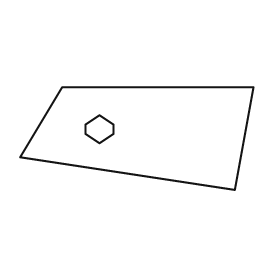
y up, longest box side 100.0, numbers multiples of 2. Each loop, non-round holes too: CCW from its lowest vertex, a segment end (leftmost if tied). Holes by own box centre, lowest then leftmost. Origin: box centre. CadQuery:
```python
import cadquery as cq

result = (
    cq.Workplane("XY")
    .moveTo(42.0, -22.0)
    .lineTo(50.0, 22.0)
    .lineTo(-32.0, 22.0)
    .lineTo(-50.0, -8.0)
    .close()
    .moveTo(-16.0, -2.0)
    .lineTo(-10.0, 2.0)
    .lineTo(-10.0, 6.0)
    .lineTo(-16.0, 10.0)
    .lineTo(-22.0, 6.0)
    .lineTo(-22.0, 2.0)
    .close()
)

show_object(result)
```